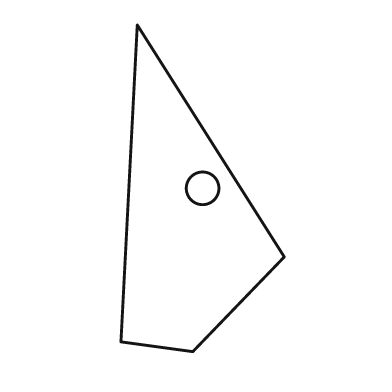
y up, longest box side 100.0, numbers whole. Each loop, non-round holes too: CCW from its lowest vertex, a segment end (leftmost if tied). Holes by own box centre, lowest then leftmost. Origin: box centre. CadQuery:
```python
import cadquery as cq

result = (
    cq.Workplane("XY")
    .moveTo(-3.0, -50.0)
    .lineTo(25.0, -21.0)
    .lineTo(-20.0, 50.0)
    .lineTo(-25.0, -47.0)
    .close()
    .moveTo(0.0, 0.0)
    .circle(5.0)
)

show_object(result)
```